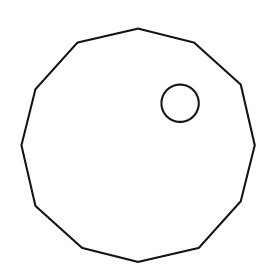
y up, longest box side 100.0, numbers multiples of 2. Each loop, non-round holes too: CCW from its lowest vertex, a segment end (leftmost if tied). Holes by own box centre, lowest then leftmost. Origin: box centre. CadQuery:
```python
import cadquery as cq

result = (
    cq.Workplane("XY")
    .moveTo(0.0, -50.0)
    .lineTo(26.0, -44.0)
    .lineTo(44.0, -24.0)
    .lineTo(50.0, 0.0)
    .lineTo(44.0, 26.0)
    .lineTo(24.0, 44.0)
    .lineTo(0.0, 50.0)
    .lineTo(-26.0, 44.0)
    .lineTo(-44.0, 24.0)
    .lineTo(-50.0, 0.0)
    .lineTo(-44.0, -26.0)
    .lineTo(-24.0, -44.0)
    .close()
    .moveTo(18.0, 18.0)
    .circle(8.0)
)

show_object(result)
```